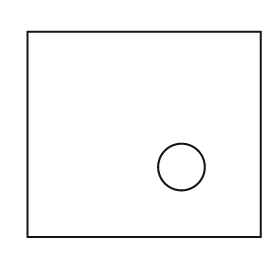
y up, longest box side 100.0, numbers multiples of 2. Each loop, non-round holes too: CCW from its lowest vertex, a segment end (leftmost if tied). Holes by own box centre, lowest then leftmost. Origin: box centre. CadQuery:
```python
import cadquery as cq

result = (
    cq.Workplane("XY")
    .moveTo(-50.0, -44.0)
    .lineTo(50.0, -44.0)
    .lineTo(50.0, 44.0)
    .lineTo(-50.0, 44.0)
    .close()
    .moveTo(16.0, -14.0)
    .circle(10.0)
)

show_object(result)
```